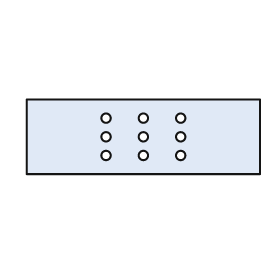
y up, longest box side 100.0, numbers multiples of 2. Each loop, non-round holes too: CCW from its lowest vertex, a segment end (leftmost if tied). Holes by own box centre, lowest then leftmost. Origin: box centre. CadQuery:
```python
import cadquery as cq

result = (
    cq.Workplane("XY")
    .moveTo(-50.0, -16.0)
    .lineTo(50.0, -16.0)
    .lineTo(50.0, 16.0)
    .lineTo(-50.0, 16.0)
    .close()
    .moveTo(-16.0, -8.0)
    .circle(2.0)
    .moveTo(0.0, -8.0)
    .circle(2.0)
    .moveTo(16.0, -8.0)
    .circle(2.0)
    .moveTo(-16.0, 0.0)
    .circle(2.0)
    .moveTo(0.0, 0.0)
    .circle(2.0)
    .moveTo(16.0, 0.0)
    .circle(2.0)
    .moveTo(-16.0, 8.0)
    .circle(2.0)
    .moveTo(0.0, 8.0)
    .circle(2.0)
    .moveTo(16.0, 8.0)
    .circle(2.0)
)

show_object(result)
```